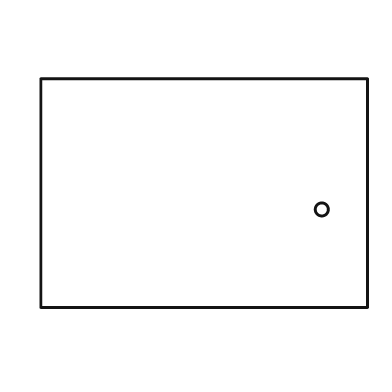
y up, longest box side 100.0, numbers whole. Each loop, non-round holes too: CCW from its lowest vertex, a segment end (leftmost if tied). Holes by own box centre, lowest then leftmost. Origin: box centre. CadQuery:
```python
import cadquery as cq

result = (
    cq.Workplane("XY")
    .moveTo(-50.0, -35.0)
    .lineTo(50.0, -35.0)
    .lineTo(50.0, 35.0)
    .lineTo(-50.0, 35.0)
    .close()
    .moveTo(36.0, -5.0)
    .circle(2.0)
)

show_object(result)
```